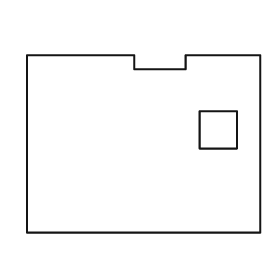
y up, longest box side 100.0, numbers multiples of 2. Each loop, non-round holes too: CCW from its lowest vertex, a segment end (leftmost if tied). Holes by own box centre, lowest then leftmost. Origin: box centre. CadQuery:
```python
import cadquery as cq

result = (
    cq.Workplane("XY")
    .moveTo(-50.0, -38.0)
    .lineTo(50.0, -38.0)
    .lineTo(50.0, 38.0)
    .lineTo(18.0, 38.0)
    .lineTo(18.0, 32.0)
    .lineTo(-4.0, 32.0)
    .lineTo(-4.0, 38.0)
    .lineTo(-50.0, 38.0)
    .close()
    .moveTo(24.0, -2.0)
    .lineTo(40.0, -2.0)
    .lineTo(40.0, 14.0)
    .lineTo(24.0, 14.0)
    .close()
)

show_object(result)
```